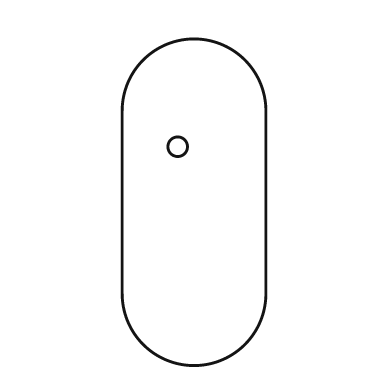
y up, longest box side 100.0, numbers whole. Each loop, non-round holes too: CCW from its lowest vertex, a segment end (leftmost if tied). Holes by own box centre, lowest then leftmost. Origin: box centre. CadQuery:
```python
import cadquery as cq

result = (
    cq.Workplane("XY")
    .moveTo(-22.0, -28.0)
    .threePointArc((0.0, -50.0), (22.0, -28.0))
    .lineTo(22.0, 28.0)
    .threePointArc((0.0, 50.0), (-22.0, 28.0))
    .close()
    .moveTo(-5.0, 17.0)
    .circle(3.0)
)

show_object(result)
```